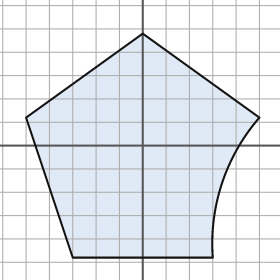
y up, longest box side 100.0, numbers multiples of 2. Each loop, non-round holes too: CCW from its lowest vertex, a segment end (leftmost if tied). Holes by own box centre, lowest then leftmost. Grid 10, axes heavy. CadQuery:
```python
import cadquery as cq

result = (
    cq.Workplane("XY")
    .moveTo(-30.0, -48.0)
    .lineTo(30.0, -48.0)
    .threePointArc((34.0, -16.0), (50.0, 12.0))
    .lineTo(0.0, 48.0)
    .lineTo(-50.0, 12.0)
    .close()
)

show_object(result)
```